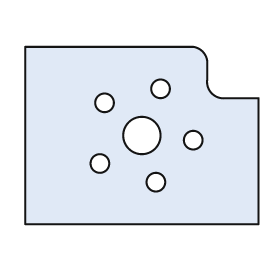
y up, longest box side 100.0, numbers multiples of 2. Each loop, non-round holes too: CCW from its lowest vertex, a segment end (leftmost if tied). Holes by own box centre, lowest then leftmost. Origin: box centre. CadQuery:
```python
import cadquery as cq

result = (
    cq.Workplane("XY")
    .moveTo(-50.0, -38.0)
    .lineTo(50.0, -38.0)
    .lineTo(50.0, 16.0)
    .lineTo(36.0, 16.0)
    .threePointArc((30.0, 18.0), (28.0, 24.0))
    .lineTo(28.0, 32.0)
    .threePointArc((26.0, 36.0), (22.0, 38.0))
    .lineTo(-50.0, 38.0)
    .close()
    .moveTo(6.0, -20.0)
    .circle(4.0)
    .moveTo(-18.0, -12.0)
    .circle(4.0)
    .moveTo(22.0, -2.0)
    .circle(4.0)
    .moveTo(0.0, 0.0)
    .circle(8.0)
    .moveTo(-16.0, 14.0)
    .circle(4.0)
    .moveTo(8.0, 20.0)
    .circle(4.0)
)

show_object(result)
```